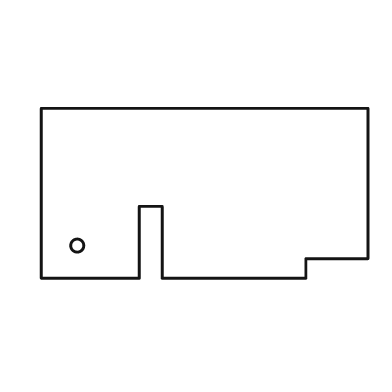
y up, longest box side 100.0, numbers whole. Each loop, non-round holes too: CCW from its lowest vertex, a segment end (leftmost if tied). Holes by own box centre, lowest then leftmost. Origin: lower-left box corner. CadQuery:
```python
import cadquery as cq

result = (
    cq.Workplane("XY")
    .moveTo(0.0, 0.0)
    .lineTo(30.0, 0.0)
    .lineTo(30.0, 22.0)
    .lineTo(37.0, 22.0)
    .lineTo(37.0, 0.0)
    .lineTo(81.0, 0.0)
    .lineTo(81.0, 6.0)
    .lineTo(100.0, 6.0)
    .lineTo(100.0, 52.0)
    .lineTo(0.0, 52.0)
    .close()
    .moveTo(11.0, 10.0)
    .circle(2.0)
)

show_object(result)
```